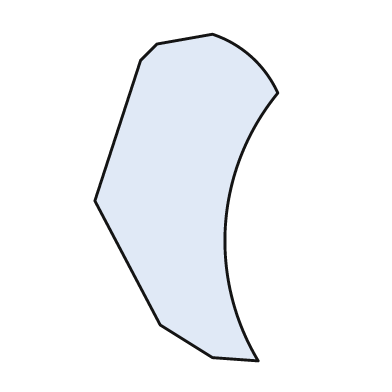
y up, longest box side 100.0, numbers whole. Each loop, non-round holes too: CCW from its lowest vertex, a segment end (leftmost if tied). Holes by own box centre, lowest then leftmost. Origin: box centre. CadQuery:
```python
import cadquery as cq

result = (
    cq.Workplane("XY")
    .moveTo(22.0, -50.0)
    .threePointArc((12.0, -8.0), (28.0, 32.0))
    .threePointArc((20.0, 43.0), (8.0, 50.0))
    .lineTo(-9.0, 47.0)
    .lineTo(-14.0, 42.0)
    .lineTo(-28.0, -1.0)
    .lineTo(-8.0, -39.0)
    .lineTo(8.0, -49.0)
    .close()
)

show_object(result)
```